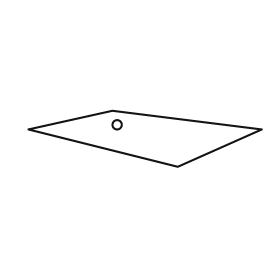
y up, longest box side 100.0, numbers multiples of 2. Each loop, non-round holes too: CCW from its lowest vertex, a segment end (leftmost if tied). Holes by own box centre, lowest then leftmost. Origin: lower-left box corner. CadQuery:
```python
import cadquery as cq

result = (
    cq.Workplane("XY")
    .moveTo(64.0, 0.0)
    .lineTo(100.0, 16.0)
    .lineTo(36.0, 24.0)
    .lineTo(0.0, 16.0)
    .close()
    .moveTo(38.0, 18.0)
    .circle(2.0)
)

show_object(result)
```